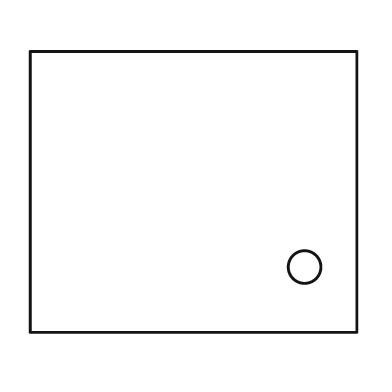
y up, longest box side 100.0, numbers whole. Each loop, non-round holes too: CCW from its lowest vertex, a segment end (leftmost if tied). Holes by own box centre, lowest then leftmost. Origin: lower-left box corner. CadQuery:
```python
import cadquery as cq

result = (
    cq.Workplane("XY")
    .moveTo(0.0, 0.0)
    .lineTo(100.0, 0.0)
    .lineTo(100.0, 86.0)
    .lineTo(0.0, 86.0)
    .close()
    .moveTo(84.0, 20.0)
    .circle(5.0)
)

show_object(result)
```